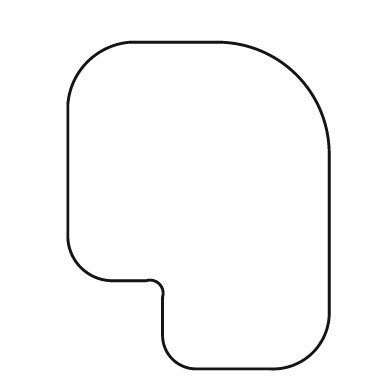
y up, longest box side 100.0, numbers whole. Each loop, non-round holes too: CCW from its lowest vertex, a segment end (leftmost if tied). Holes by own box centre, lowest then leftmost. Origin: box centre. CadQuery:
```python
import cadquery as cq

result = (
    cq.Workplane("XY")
    .moveTo(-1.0, -50.0)
    .lineTo(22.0, -50.0)
    .threePointArc((35.0, -45.0), (40.0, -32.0))
    .lineTo(40.0, 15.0)
    .threePointArc((30.0, 40.0), (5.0, 50.0))
    .lineTo(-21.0, 50.0)
    .threePointArc((-34.0, 44.0), (-40.0, 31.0))
    .lineTo(-40.0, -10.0)
    .threePointArc((-36.0, -19.0), (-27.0, -23.0))
    .lineTo(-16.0, -23.0)
    .threePointArc((-12.0, -24.0), (-11.0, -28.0))
    .lineTo(-11.0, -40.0)
    .threePointArc((-8.0, -47.0), (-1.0, -50.0))
    .close()
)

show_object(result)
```